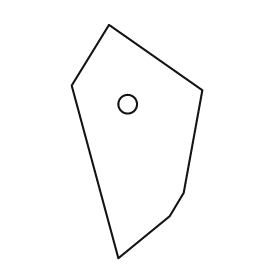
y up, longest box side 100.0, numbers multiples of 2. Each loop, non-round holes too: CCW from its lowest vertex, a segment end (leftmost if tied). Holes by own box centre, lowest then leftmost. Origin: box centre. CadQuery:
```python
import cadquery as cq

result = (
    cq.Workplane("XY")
    .moveTo(-8.0, -50.0)
    .lineTo(14.0, -32.0)
    .lineTo(20.0, -22.0)
    .lineTo(28.0, 22.0)
    .lineTo(-12.0, 50.0)
    .lineTo(-28.0, 24.0)
    .close()
    .moveTo(-4.0, 16.0)
    .circle(4.0)
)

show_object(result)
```